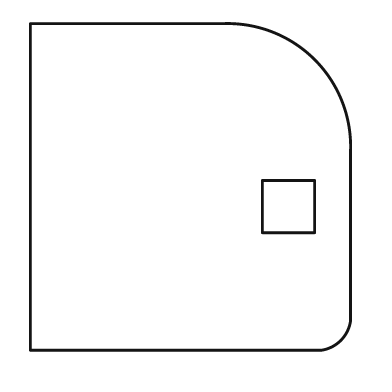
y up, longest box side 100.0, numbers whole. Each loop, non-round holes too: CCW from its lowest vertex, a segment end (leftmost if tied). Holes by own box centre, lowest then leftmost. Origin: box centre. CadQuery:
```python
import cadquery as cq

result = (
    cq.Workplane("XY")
    .moveTo(-49.0, -50.0)
    .lineTo(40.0, -50.0)
    .threePointArc((46.0, -47.0), (49.0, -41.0))
    .lineTo(49.0, 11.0)
    .threePointArc((38.0, 39.0), (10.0, 50.0))
    .lineTo(-49.0, 50.0)
    .close()
    .moveTo(22.0, -14.0)
    .lineTo(38.0, -14.0)
    .lineTo(38.0, 2.0)
    .lineTo(22.0, 2.0)
    .close()
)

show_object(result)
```